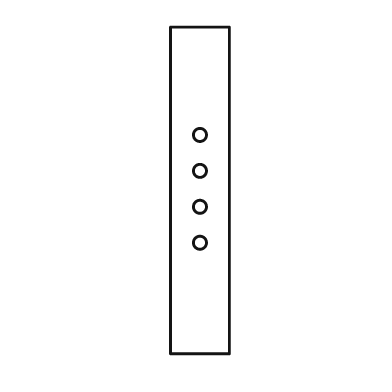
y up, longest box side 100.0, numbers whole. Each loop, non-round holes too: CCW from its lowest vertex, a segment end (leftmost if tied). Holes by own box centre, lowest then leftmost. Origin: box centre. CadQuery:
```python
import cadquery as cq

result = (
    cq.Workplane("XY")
    .moveTo(-9.0, -50.0)
    .lineTo(9.0, -50.0)
    .lineTo(9.0, 50.0)
    .lineTo(-9.0, 50.0)
    .close()
    .moveTo(0.0, -16.0)
    .circle(2.0)
    .moveTo(0.0, -5.0)
    .circle(2.0)
    .moveTo(0.0, 6.0)
    .circle(2.0)
    .moveTo(0.0, 17.0)
    .circle(2.0)
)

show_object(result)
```